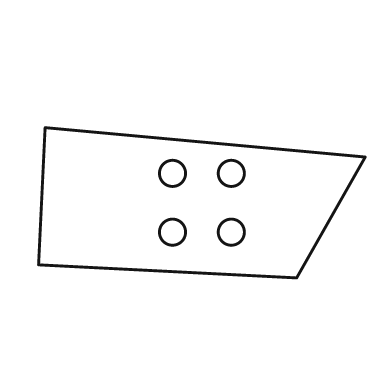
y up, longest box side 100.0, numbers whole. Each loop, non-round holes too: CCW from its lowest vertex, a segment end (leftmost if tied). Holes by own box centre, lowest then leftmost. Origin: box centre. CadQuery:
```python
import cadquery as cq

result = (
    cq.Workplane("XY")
    .moveTo(29.0, -23.0)
    .lineTo(50.0, 14.0)
    .lineTo(-48.0, 23.0)
    .lineTo(-50.0, -19.0)
    .close()
    .moveTo(-9.0, -9.0)
    .circle(4.0)
    .moveTo(9.0, -9.0)
    .circle(4.0)
    .moveTo(-9.0, 9.0)
    .circle(4.0)
    .moveTo(9.0, 9.0)
    .circle(4.0)
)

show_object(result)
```